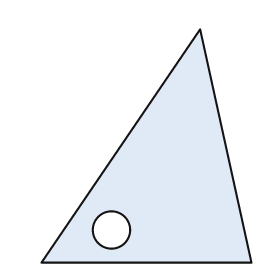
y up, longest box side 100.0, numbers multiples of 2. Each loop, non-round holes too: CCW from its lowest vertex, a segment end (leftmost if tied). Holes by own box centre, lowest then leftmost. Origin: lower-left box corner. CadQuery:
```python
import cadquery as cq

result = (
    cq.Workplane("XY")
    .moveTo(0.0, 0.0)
    .lineTo(90.0, 0.0)
    .lineTo(68.0, 100.0)
    .close()
    .moveTo(30.0, 14.0)
    .circle(8.0)
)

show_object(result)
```